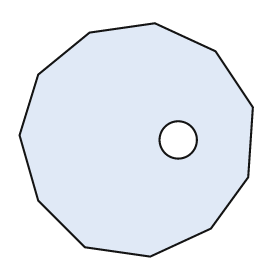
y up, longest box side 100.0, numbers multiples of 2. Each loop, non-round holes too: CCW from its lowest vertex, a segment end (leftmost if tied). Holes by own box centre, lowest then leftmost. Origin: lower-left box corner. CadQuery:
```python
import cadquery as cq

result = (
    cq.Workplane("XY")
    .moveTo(56.0, 0.0)
    .lineTo(82.0, 12.0)
    .lineTo(98.0, 34.0)
    .lineTo(100.0, 64.0)
    .lineTo(84.0, 88.0)
    .lineTo(58.0, 100.0)
    .lineTo(30.0, 96.0)
    .lineTo(8.0, 78.0)
    .lineTo(0.0, 52.0)
    .lineTo(8.0, 24.0)
    .lineTo(28.0, 4.0)
    .close()
    .moveTo(68.0, 50.0)
    .circle(8.0)
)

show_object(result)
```